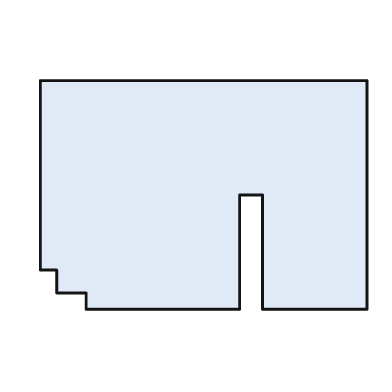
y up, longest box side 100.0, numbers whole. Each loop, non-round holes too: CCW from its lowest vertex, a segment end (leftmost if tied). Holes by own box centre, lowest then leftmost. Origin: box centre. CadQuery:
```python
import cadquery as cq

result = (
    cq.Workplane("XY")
    .moveTo(-36.0, -35.0)
    .lineTo(11.0, -35.0)
    .lineTo(11.0, 0.0)
    .lineTo(18.0, 0.0)
    .lineTo(18.0, -35.0)
    .lineTo(50.0, -35.0)
    .lineTo(50.0, 35.0)
    .lineTo(-50.0, 35.0)
    .lineTo(-50.0, -23.0)
    .lineTo(-45.0, -23.0)
    .lineTo(-45.0, -30.0)
    .lineTo(-36.0, -30.0)
    .close()
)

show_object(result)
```